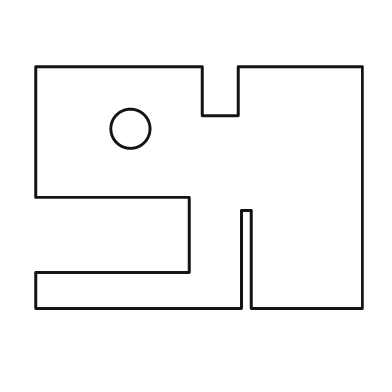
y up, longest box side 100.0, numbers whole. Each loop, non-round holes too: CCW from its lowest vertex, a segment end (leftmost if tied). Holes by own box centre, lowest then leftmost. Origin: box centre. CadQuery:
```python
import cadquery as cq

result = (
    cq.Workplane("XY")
    .moveTo(-50.0, -37.0)
    .lineTo(13.0, -37.0)
    .lineTo(13.0, -7.0)
    .lineTo(16.0, -7.0)
    .lineTo(16.0, -37.0)
    .lineTo(50.0, -37.0)
    .lineTo(50.0, 37.0)
    .lineTo(12.0, 37.0)
    .lineTo(12.0, 22.0)
    .lineTo(1.0, 22.0)
    .lineTo(1.0, 37.0)
    .lineTo(-50.0, 37.0)
    .lineTo(-50.0, -3.0)
    .lineTo(-3.0, -3.0)
    .lineTo(-3.0, -26.0)
    .lineTo(-50.0, -26.0)
    .close()
    .moveTo(-21.0, 18.0)
    .circle(6.0)
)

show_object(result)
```